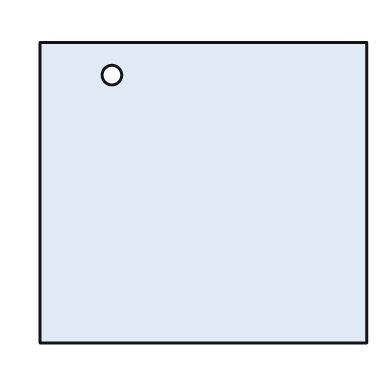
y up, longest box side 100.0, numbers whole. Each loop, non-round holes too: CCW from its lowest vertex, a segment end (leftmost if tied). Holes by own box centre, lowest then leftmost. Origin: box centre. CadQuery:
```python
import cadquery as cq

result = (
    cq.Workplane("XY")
    .moveTo(-50.0, -46.0)
    .lineTo(50.0, -46.0)
    .lineTo(50.0, 46.0)
    .lineTo(-50.0, 46.0)
    .close()
    .moveTo(-28.0, 36.0)
    .circle(3.0)
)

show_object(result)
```